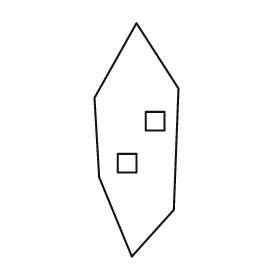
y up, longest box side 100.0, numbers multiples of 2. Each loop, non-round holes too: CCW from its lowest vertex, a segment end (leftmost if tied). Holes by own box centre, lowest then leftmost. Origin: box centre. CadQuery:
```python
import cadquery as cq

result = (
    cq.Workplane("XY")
    .moveTo(-2.0, -50.0)
    .lineTo(16.0, -30.0)
    .lineTo(18.0, 22.0)
    .lineTo(0.0, 50.0)
    .lineTo(-18.0, 18.0)
    .lineTo(-16.0, -16.0)
    .close()
    .moveTo(-8.0, -14.0)
    .lineTo(0.0, -14.0)
    .lineTo(0.0, -6.0)
    .lineTo(-8.0, -6.0)
    .close()
    .moveTo(4.0, 4.0)
    .lineTo(12.0, 4.0)
    .lineTo(12.0, 12.0)
    .lineTo(4.0, 12.0)
    .close()
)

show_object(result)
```